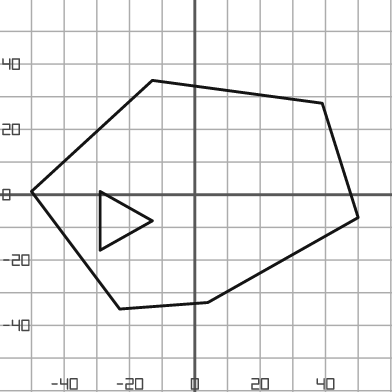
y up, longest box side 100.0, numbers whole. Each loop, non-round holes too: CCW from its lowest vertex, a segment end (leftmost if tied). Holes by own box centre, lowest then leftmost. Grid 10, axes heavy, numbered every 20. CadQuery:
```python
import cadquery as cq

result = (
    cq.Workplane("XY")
    .moveTo(-23.0, -35.0)
    .lineTo(4.0, -33.0)
    .lineTo(50.0, -7.0)
    .lineTo(39.0, 28.0)
    .lineTo(-13.0, 35.0)
    .lineTo(-50.0, 1.0)
    .close()
    .moveTo(-29.0, -17.0)
    .lineTo(-13.0, -8.0)
    .lineTo(-29.0, 1.0)
    .close()
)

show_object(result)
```